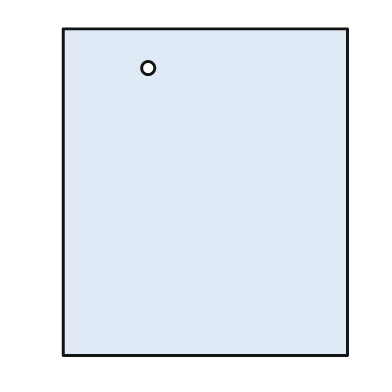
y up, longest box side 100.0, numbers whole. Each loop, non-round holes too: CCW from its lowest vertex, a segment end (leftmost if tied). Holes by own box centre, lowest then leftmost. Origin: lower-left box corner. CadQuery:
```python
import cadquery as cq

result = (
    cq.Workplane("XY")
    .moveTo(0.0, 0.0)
    .lineTo(87.0, 0.0)
    .lineTo(87.0, 100.0)
    .lineTo(0.0, 100.0)
    .close()
    .moveTo(26.0, 88.0)
    .circle(2.0)
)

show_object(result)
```